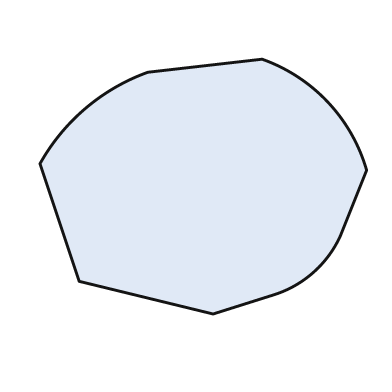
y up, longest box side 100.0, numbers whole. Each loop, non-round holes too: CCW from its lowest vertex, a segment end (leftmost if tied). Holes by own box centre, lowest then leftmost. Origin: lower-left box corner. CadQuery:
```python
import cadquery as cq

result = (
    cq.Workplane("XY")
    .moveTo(53.0, 0.0)
    .lineTo(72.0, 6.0)
    .threePointArc((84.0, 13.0), (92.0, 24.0))
    .lineTo(100.0, 44.0)
    .threePointArc((88.0, 65.0), (68.0, 78.0))
    .lineTo(33.0, 74.0)
    .threePointArc((14.0, 63.0), (0.0, 46.0))
    .lineTo(12.0, 10.0)
    .close()
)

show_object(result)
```